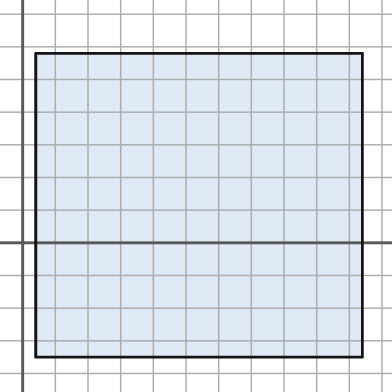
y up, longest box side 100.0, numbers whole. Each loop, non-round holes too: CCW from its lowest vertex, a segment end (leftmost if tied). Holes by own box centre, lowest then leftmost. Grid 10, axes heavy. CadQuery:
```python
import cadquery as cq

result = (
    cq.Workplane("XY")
    .moveTo(4.0, -35.0)
    .lineTo(104.0, -35.0)
    .lineTo(104.0, 58.0)
    .lineTo(4.0, 58.0)
    .close()
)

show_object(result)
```